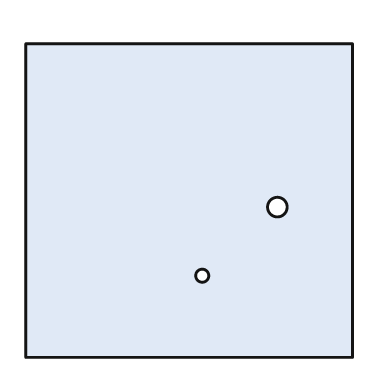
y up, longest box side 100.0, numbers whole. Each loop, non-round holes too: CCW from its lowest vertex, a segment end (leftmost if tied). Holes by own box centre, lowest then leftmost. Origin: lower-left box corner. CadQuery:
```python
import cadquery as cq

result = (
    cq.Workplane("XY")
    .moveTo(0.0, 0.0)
    .lineTo(100.0, 0.0)
    .lineTo(100.0, 96.0)
    .lineTo(0.0, 96.0)
    .close()
    .moveTo(54.0, 25.0)
    .circle(2.0)
    .moveTo(77.0, 46.0)
    .circle(3.0)
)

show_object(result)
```